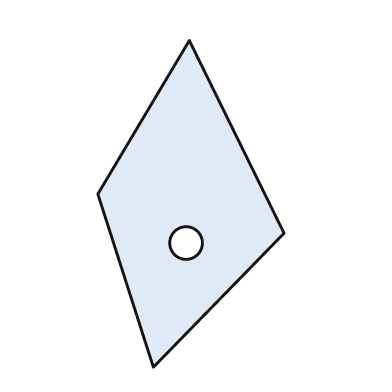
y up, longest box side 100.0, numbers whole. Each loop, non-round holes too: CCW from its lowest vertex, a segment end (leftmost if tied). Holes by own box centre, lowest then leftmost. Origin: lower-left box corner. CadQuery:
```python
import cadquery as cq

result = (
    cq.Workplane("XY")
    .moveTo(17.0, 0.0)
    .lineTo(57.0, 41.0)
    .lineTo(28.0, 100.0)
    .lineTo(0.0, 53.0)
    .close()
    .moveTo(27.0, 38.0)
    .circle(5.0)
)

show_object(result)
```